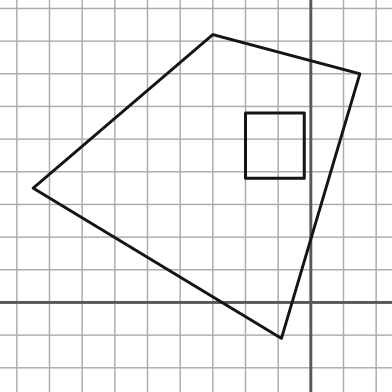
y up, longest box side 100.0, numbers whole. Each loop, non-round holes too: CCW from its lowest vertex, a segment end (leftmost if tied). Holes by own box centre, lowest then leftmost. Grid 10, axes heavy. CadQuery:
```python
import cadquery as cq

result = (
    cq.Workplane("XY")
    .moveTo(-9.0, -11.0)
    .lineTo(15.0, 70.0)
    .lineTo(-30.0, 82.0)
    .lineTo(-85.0, 35.0)
    .close()
    .moveTo(-20.0, 38.0)
    .lineTo(-2.0, 38.0)
    .lineTo(-2.0, 58.0)
    .lineTo(-20.0, 58.0)
    .close()
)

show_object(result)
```